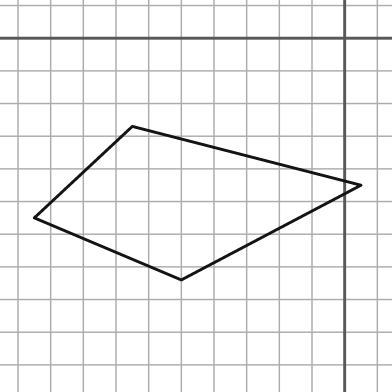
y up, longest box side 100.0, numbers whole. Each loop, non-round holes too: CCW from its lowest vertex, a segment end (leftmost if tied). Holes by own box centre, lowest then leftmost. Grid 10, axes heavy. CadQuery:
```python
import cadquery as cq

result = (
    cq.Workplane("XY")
    .moveTo(-50.0, -74.0)
    .lineTo(5.0, -45.0)
    .lineTo(-65.0, -27.0)
    .lineTo(-95.0, -55.0)
    .close()
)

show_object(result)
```